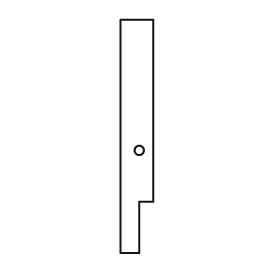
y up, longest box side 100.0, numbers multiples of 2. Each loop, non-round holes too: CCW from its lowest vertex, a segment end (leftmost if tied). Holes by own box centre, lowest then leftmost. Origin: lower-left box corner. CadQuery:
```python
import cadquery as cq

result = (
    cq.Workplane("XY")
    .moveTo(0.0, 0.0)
    .lineTo(8.0, 0.0)
    .lineTo(8.0, 22.0)
    .lineTo(14.0, 22.0)
    .lineTo(14.0, 100.0)
    .lineTo(0.0, 100.0)
    .close()
    .moveTo(8.0, 44.0)
    .circle(2.0)
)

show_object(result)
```